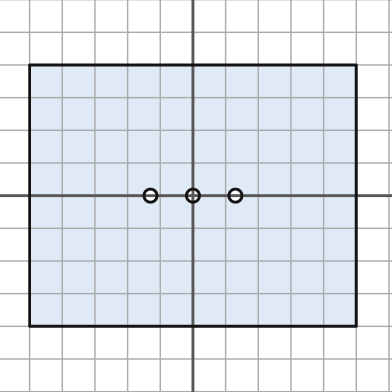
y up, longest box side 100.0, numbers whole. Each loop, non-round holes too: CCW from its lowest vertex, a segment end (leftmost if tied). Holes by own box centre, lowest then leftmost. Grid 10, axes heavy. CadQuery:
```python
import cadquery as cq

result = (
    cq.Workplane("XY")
    .moveTo(-50.0, -40.0)
    .lineTo(50.0, -40.0)
    .lineTo(50.0, 40.0)
    .lineTo(-50.0, 40.0)
    .close()
    .moveTo(-13.0, 0.0)
    .circle(2.0)
    .moveTo(0.0, 0.0)
    .circle(2.0)
    .moveTo(13.0, 0.0)
    .circle(2.0)
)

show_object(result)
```